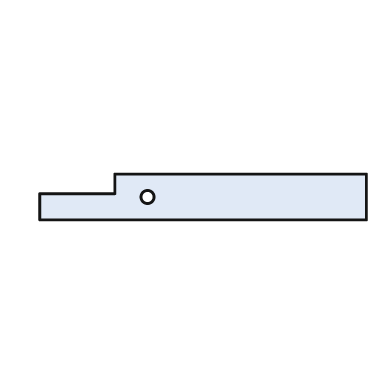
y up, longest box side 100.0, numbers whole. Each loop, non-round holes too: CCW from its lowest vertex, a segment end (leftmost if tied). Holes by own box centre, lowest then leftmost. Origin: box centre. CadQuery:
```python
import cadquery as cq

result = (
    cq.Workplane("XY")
    .moveTo(-50.0, -7.0)
    .lineTo(50.0, -7.0)
    .lineTo(50.0, 7.0)
    .lineTo(-27.0, 7.0)
    .lineTo(-27.0, 1.0)
    .lineTo(-50.0, 1.0)
    .close()
    .moveTo(-17.0, 0.0)
    .circle(2.0)
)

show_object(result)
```